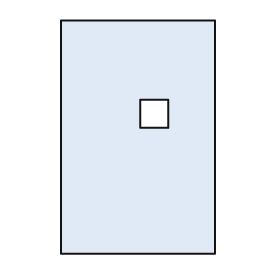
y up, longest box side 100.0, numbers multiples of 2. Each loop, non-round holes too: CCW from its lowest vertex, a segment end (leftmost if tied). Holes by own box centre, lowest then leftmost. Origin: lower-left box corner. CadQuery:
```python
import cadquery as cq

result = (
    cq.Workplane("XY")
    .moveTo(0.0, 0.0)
    .lineTo(66.0, 0.0)
    .lineTo(66.0, 100.0)
    .lineTo(0.0, 100.0)
    .close()
    .moveTo(34.0, 54.0)
    .lineTo(46.0, 54.0)
    .lineTo(46.0, 66.0)
    .lineTo(34.0, 66.0)
    .close()
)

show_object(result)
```